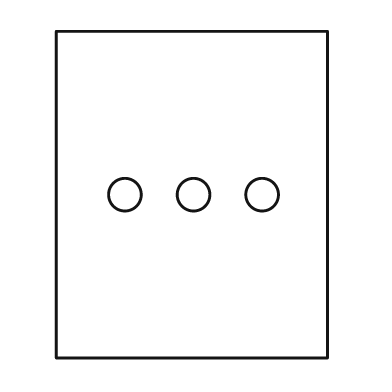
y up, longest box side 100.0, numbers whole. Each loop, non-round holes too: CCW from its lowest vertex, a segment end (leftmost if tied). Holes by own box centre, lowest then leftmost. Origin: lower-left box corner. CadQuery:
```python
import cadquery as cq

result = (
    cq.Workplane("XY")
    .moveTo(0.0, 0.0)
    .lineTo(83.0, 0.0)
    .lineTo(83.0, 100.0)
    .lineTo(0.0, 100.0)
    .close()
    .moveTo(21.0, 50.0)
    .circle(5.0)
    .moveTo(42.0, 50.0)
    .circle(5.0)
    .moveTo(63.0, 50.0)
    .circle(5.0)
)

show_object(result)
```